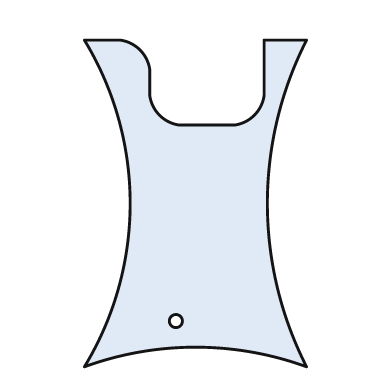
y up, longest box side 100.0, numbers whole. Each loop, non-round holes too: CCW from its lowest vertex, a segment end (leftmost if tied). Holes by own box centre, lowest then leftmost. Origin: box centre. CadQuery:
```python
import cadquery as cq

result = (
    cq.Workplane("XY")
    .moveTo(-34.0, -50.0)
    .threePointArc((0.0, -44.0), (34.0, -50.0))
    .threePointArc((22.0, 0.0), (34.0, 50.0))
    .lineTo(21.0, 50.0)
    .lineTo(21.0, 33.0)
    .threePointArc((18.0, 27.0), (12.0, 24.0))
    .lineTo(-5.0, 24.0)
    .threePointArc((-11.0, 27.0), (-14.0, 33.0))
    .lineTo(-14.0, 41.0)
    .threePointArc((-17.0, 47.0), (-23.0, 50.0))
    .lineTo(-34.0, 50.0)
    .threePointArc((-20.0, 0.0), (-34.0, -50.0))
    .close()
    .moveTo(-6.0, -36.0)
    .circle(2.0)
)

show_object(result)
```